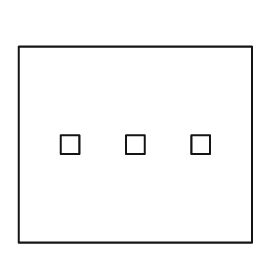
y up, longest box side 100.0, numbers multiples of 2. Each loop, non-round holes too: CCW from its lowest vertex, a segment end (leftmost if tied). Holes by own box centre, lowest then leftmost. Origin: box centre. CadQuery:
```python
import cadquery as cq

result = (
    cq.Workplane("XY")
    .moveTo(-50.0, -42.0)
    .lineTo(50.0, -42.0)
    .lineTo(50.0, 42.0)
    .lineTo(-50.0, 42.0)
    .close()
    .moveTo(-32.0, -4.0)
    .lineTo(-24.0, -4.0)
    .lineTo(-24.0, 4.0)
    .lineTo(-32.0, 4.0)
    .close()
    .moveTo(-4.0, -4.0)
    .lineTo(4.0, -4.0)
    .lineTo(4.0, 4.0)
    .lineTo(-4.0, 4.0)
    .close()
    .moveTo(24.0, -4.0)
    .lineTo(32.0, -4.0)
    .lineTo(32.0, 4.0)
    .lineTo(24.0, 4.0)
    .close()
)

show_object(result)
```